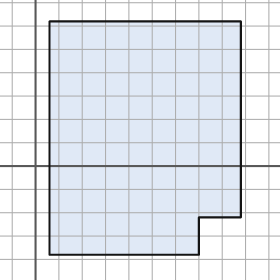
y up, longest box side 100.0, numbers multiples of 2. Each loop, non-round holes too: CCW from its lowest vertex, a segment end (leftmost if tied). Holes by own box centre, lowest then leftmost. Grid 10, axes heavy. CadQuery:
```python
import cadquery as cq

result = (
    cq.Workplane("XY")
    .moveTo(6.0, -38.0)
    .lineTo(70.0, -38.0)
    .lineTo(70.0, -22.0)
    .lineTo(88.0, -22.0)
    .lineTo(88.0, 62.0)
    .lineTo(6.0, 62.0)
    .close()
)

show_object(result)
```